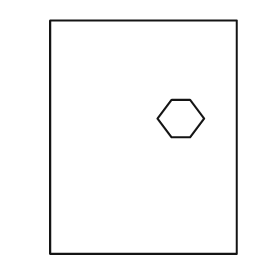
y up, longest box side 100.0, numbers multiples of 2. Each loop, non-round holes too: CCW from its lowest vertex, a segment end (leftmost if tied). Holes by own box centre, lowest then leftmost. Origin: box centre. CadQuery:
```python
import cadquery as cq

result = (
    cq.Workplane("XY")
    .moveTo(-40.0, -50.0)
    .lineTo(40.0, -50.0)
    .lineTo(40.0, 50.0)
    .lineTo(-40.0, 50.0)
    .close()
    .moveTo(12.0, 0.0)
    .lineTo(20.0, 0.0)
    .lineTo(26.0, 8.0)
    .lineTo(20.0, 16.0)
    .lineTo(12.0, 16.0)
    .lineTo(6.0, 8.0)
    .close()
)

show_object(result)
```